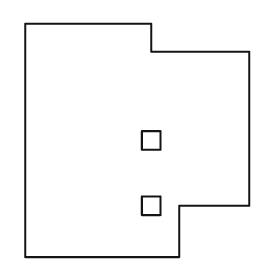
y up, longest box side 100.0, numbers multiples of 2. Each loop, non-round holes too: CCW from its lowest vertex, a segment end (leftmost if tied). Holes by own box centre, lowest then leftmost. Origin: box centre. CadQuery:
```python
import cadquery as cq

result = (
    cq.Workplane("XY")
    .moveTo(-48.0, -50.0)
    .lineTo(18.0, -50.0)
    .lineTo(18.0, -28.0)
    .lineTo(48.0, -28.0)
    .lineTo(48.0, 38.0)
    .lineTo(6.0, 38.0)
    .lineTo(6.0, 50.0)
    .lineTo(-48.0, 50.0)
    .close()
    .moveTo(2.0, -32.0)
    .lineTo(10.0, -32.0)
    .lineTo(10.0, -24.0)
    .lineTo(2.0, -24.0)
    .close()
    .moveTo(2.0, -4.0)
    .lineTo(10.0, -4.0)
    .lineTo(10.0, 4.0)
    .lineTo(2.0, 4.0)
    .close()
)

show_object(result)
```